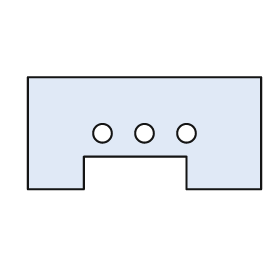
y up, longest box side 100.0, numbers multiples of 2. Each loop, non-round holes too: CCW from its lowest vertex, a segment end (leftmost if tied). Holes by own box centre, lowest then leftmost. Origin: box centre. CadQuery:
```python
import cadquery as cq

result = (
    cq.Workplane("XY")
    .moveTo(-50.0, -24.0)
    .lineTo(-26.0, -24.0)
    .lineTo(-26.0, -10.0)
    .lineTo(18.0, -10.0)
    .lineTo(18.0, -24.0)
    .lineTo(50.0, -24.0)
    .lineTo(50.0, 24.0)
    .lineTo(-50.0, 24.0)
    .close()
    .moveTo(-18.0, 0.0)
    .circle(4.0)
    .moveTo(0.0, 0.0)
    .circle(4.0)
    .moveTo(18.0, 0.0)
    .circle(4.0)
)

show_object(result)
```